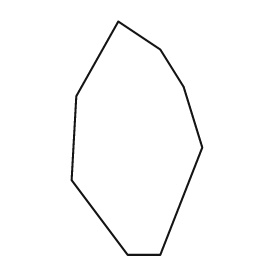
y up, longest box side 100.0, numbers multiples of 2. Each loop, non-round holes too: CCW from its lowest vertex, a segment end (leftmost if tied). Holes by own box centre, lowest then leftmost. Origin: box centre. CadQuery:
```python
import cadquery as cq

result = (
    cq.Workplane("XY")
    .moveTo(-4.0, -50.0)
    .lineTo(10.0, -50.0)
    .lineTo(28.0, -4.0)
    .lineTo(20.0, 22.0)
    .lineTo(10.0, 38.0)
    .lineTo(-8.0, 50.0)
    .lineTo(-26.0, 18.0)
    .lineTo(-28.0, -18.0)
    .close()
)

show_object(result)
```